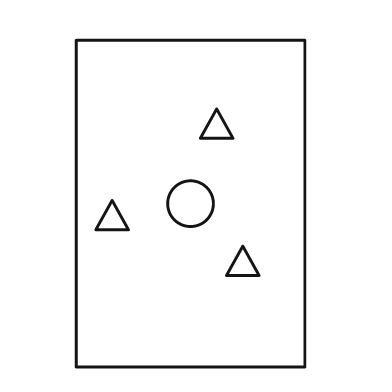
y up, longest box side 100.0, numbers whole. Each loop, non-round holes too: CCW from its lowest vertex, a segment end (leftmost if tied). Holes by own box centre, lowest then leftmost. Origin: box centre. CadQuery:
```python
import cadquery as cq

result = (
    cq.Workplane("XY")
    .moveTo(-35.0, -50.0)
    .lineTo(35.0, -50.0)
    .lineTo(35.0, 50.0)
    .lineTo(-35.0, 50.0)
    .close()
    .moveTo(11.0, -22.0)
    .lineTo(21.0, -22.0)
    .lineTo(16.0, -13.0)
    .close()
    .moveTo(-29.0, -8.0)
    .lineTo(-19.0, -8.0)
    .lineTo(-24.0, 1.0)
    .close()
    .moveTo(0.0, 0.0)
    .circle(7.0)
    .moveTo(3.0, 20.0)
    .lineTo(13.0, 20.0)
    .lineTo(8.0, 29.0)
    .close()
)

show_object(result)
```